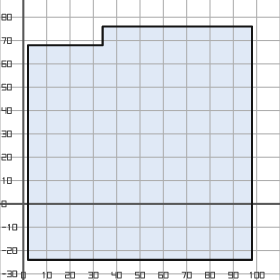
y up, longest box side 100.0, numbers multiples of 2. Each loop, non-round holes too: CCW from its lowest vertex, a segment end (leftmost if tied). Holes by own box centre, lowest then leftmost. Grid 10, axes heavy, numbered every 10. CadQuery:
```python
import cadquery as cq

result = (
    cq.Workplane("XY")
    .moveTo(2.0, -24.0)
    .lineTo(98.0, -24.0)
    .lineTo(98.0, 76.0)
    .lineTo(34.0, 76.0)
    .lineTo(34.0, 68.0)
    .lineTo(2.0, 68.0)
    .close()
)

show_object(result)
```